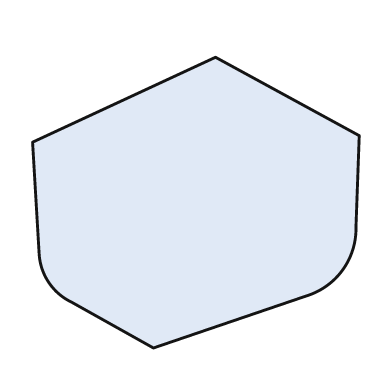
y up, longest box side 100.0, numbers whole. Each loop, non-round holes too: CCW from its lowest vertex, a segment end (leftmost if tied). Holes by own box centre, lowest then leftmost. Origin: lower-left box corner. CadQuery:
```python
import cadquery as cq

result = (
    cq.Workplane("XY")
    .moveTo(37.0, 0.0)
    .lineTo(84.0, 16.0)
    .threePointArc((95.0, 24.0), (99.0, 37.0))
    .lineTo(100.0, 65.0)
    .lineTo(56.0, 89.0)
    .lineTo(0.0, 63.0)
    .lineTo(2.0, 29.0)
    .threePointArc((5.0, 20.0), (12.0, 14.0))
    .close()
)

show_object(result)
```